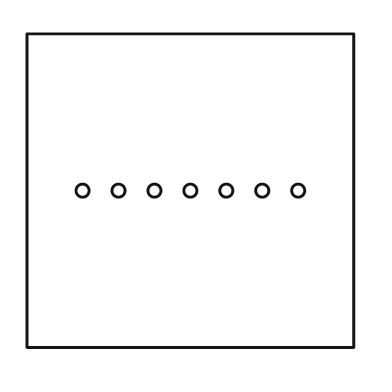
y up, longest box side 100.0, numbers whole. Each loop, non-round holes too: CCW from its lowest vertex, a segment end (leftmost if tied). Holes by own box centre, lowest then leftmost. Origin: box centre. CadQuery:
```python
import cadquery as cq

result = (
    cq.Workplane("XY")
    .moveTo(-50.0, -48.0)
    .lineTo(50.0, -48.0)
    .lineTo(50.0, 48.0)
    .lineTo(-50.0, 48.0)
    .close()
    .moveTo(-33.0, 0.0)
    .circle(2.0)
    .moveTo(-22.0, 0.0)
    .circle(2.0)
    .moveTo(-11.0, 0.0)
    .circle(2.0)
    .moveTo(0.0, 0.0)
    .circle(2.0)
    .moveTo(11.0, 0.0)
    .circle(2.0)
    .moveTo(22.0, 0.0)
    .circle(2.0)
    .moveTo(33.0, 0.0)
    .circle(2.0)
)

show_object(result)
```